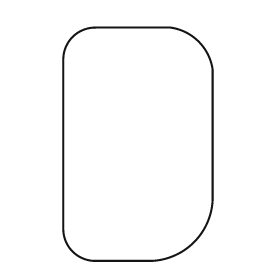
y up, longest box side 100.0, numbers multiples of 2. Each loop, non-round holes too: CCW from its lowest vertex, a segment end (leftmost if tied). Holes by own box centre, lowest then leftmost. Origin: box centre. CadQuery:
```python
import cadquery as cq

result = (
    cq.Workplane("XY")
    .moveTo(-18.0, -50.0)
    .lineTo(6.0, -50.0)
    .threePointArc((24.0, -42.0), (32.0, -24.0))
    .lineTo(32.0, 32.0)
    .threePointArc((26.0, 44.0), (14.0, 50.0))
    .lineTo(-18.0, 50.0)
    .threePointArc((-28.0, 46.0), (-32.0, 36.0))
    .lineTo(-32.0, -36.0)
    .threePointArc((-28.0, -46.0), (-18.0, -50.0))
    .close()
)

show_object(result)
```